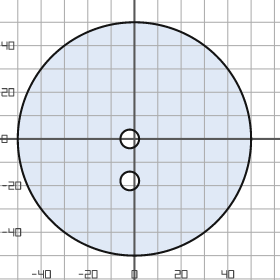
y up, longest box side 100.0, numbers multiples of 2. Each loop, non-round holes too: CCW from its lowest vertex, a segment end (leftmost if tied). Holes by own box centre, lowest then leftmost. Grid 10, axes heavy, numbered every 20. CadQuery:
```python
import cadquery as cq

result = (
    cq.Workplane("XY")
    .moveTo(0.0, 0.0)
    .circle(50.0)
    .moveTo(-2.0, -18.0)
    .circle(4.0)
    .moveTo(-2.0, 0.0)
    .circle(4.0)
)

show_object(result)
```